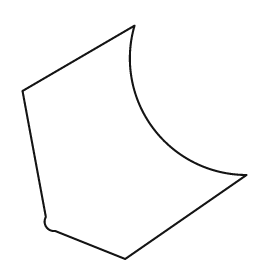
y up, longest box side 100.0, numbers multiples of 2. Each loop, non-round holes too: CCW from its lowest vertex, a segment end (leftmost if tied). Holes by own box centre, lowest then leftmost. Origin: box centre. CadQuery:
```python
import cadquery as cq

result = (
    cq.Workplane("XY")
    .moveTo(-4.0, -50.0)
    .lineTo(48.0, -14.0)
    .threePointArc((8.0, 6.0), (0.0, 50.0))
    .lineTo(-48.0, 22.0)
    .lineTo(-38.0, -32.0)
    .threePointArc((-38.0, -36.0), (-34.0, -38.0))
    .close()
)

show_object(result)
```